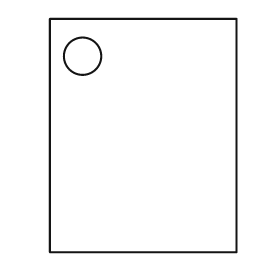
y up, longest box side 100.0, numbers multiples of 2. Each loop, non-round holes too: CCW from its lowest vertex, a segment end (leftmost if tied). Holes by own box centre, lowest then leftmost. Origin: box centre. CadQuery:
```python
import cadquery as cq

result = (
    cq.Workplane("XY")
    .moveTo(-40.0, -50.0)
    .lineTo(40.0, -50.0)
    .lineTo(40.0, 50.0)
    .lineTo(-40.0, 50.0)
    .close()
    .moveTo(-26.0, 34.0)
    .circle(8.0)
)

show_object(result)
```